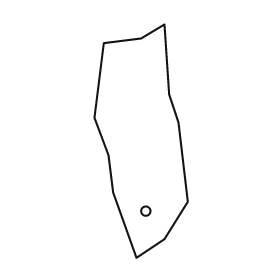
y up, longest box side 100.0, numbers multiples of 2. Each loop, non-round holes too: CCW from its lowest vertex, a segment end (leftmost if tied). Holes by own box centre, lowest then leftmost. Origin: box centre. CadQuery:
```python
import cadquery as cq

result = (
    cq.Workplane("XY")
    .moveTo(-2.0, -50.0)
    .lineTo(10.0, -42.0)
    .lineTo(20.0, -26.0)
    .lineTo(16.0, 8.0)
    .lineTo(12.0, 20.0)
    .lineTo(10.0, 50.0)
    .lineTo(0.0, 44.0)
    .lineTo(-16.0, 42.0)
    .lineTo(-20.0, 10.0)
    .lineTo(-14.0, -6.0)
    .lineTo(-12.0, -22.0)
    .close()
    .moveTo(2.0, -30.0)
    .circle(2.0)
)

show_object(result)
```